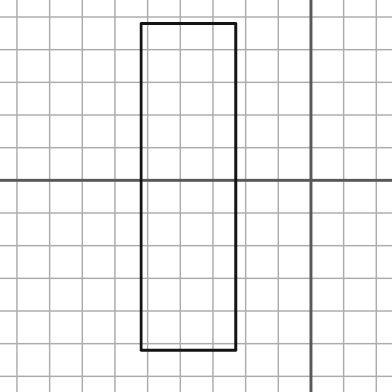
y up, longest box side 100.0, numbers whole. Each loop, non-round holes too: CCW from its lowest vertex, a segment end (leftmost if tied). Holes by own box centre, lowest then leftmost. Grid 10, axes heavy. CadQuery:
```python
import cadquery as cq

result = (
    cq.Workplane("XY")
    .moveTo(-52.0, -52.0)
    .lineTo(-23.0, -52.0)
    .lineTo(-23.0, 48.0)
    .lineTo(-52.0, 48.0)
    .close()
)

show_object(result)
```